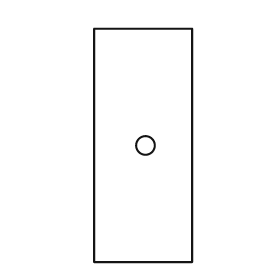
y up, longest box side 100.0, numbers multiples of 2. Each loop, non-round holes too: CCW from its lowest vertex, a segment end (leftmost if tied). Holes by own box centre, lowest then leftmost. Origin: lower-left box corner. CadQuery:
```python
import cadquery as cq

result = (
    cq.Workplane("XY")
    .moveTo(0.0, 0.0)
    .lineTo(42.0, 0.0)
    .lineTo(42.0, 100.0)
    .lineTo(0.0, 100.0)
    .close()
    .moveTo(22.0, 50.0)
    .circle(4.0)
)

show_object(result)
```